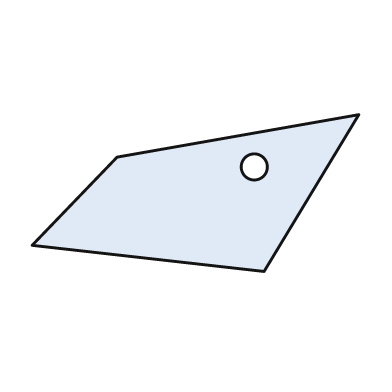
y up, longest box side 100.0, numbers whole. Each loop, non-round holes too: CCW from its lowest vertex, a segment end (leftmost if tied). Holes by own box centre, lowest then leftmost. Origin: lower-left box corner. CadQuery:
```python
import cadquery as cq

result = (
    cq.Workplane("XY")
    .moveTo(71.0, 0.0)
    .lineTo(100.0, 48.0)
    .lineTo(26.0, 35.0)
    .lineTo(0.0, 8.0)
    .close()
    .moveTo(68.0, 32.0)
    .circle(4.0)
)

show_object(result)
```